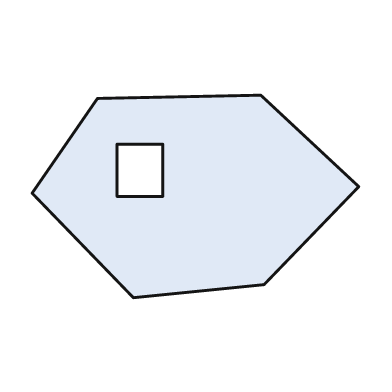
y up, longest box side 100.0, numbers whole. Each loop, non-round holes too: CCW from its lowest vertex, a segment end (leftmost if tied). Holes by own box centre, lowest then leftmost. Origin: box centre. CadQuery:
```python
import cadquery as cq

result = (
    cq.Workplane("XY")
    .moveTo(-19.0, -31.0)
    .lineTo(21.0, -27.0)
    .lineTo(50.0, 3.0)
    .lineTo(20.0, 31.0)
    .lineTo(-30.0, 30.0)
    .lineTo(-50.0, 1.0)
    .close()
    .moveTo(-24.0, 0.0)
    .lineTo(-10.0, 0.0)
    .lineTo(-10.0, 16.0)
    .lineTo(-24.0, 16.0)
    .close()
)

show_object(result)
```